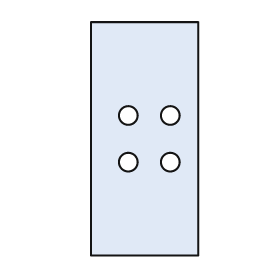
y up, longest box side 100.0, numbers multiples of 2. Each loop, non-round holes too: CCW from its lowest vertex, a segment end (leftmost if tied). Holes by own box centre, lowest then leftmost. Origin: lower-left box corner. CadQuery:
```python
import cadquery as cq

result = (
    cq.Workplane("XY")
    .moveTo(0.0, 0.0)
    .lineTo(46.0, 0.0)
    .lineTo(46.0, 100.0)
    .lineTo(0.0, 100.0)
    .close()
    .moveTo(16.0, 40.0)
    .circle(4.0)
    .moveTo(34.0, 40.0)
    .circle(4.0)
    .moveTo(16.0, 60.0)
    .circle(4.0)
    .moveTo(34.0, 60.0)
    .circle(4.0)
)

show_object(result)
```